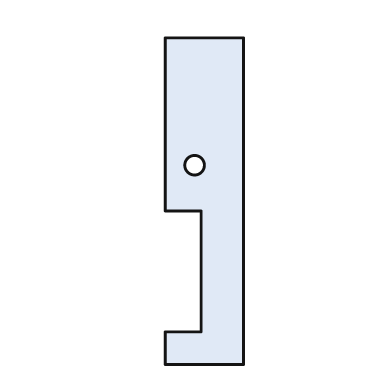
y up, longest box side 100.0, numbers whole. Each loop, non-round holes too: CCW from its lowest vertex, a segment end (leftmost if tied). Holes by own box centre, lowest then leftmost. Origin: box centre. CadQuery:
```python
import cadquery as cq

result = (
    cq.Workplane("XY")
    .moveTo(-12.0, -50.0)
    .lineTo(12.0, -50.0)
    .lineTo(12.0, 50.0)
    .lineTo(-12.0, 50.0)
    .lineTo(-12.0, -3.0)
    .lineTo(-1.0, -3.0)
    .lineTo(-1.0, -40.0)
    .lineTo(-12.0, -40.0)
    .close()
    .moveTo(-3.0, 11.0)
    .circle(3.0)
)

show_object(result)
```